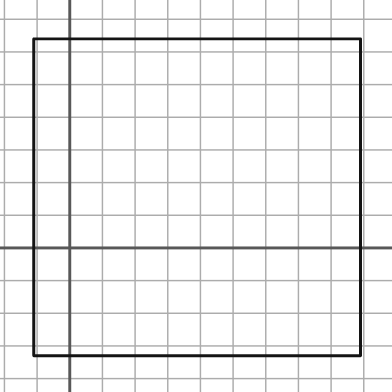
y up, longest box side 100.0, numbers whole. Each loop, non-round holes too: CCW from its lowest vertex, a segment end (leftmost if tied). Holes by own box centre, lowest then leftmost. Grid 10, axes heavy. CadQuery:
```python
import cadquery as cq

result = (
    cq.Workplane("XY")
    .moveTo(-11.0, -33.0)
    .lineTo(89.0, -33.0)
    .lineTo(89.0, 64.0)
    .lineTo(-11.0, 64.0)
    .close()
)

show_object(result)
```